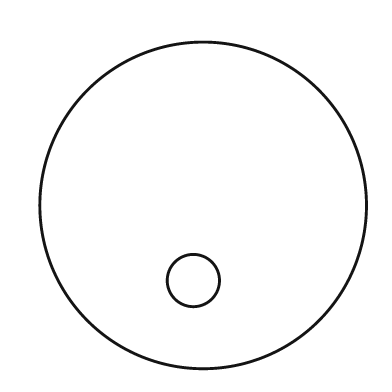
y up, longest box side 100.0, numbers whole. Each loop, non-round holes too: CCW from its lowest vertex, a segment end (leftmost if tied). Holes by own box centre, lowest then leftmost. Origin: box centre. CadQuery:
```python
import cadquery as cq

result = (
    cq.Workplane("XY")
    .moveTo(0.0, 0.0)
    .circle(50.0)
    .moveTo(-3.0, -23.0)
    .circle(8.0)
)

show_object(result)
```